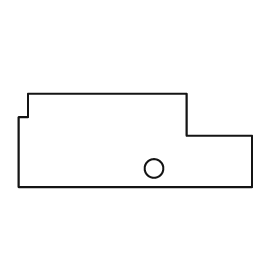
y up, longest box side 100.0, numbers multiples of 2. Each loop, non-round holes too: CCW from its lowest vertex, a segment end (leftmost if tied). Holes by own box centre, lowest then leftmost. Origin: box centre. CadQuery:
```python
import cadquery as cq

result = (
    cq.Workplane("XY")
    .moveTo(-50.0, -20.0)
    .lineTo(50.0, -20.0)
    .lineTo(50.0, 2.0)
    .lineTo(22.0, 2.0)
    .lineTo(22.0, 20.0)
    .lineTo(-46.0, 20.0)
    .lineTo(-46.0, 10.0)
    .lineTo(-50.0, 10.0)
    .close()
    .moveTo(8.0, -12.0)
    .circle(4.0)
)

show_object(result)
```